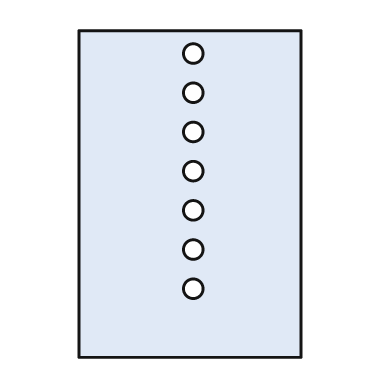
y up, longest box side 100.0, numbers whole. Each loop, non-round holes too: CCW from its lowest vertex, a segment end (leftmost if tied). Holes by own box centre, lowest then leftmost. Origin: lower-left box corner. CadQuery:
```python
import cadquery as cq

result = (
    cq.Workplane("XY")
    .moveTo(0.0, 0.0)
    .lineTo(68.0, 0.0)
    .lineTo(68.0, 100.0)
    .lineTo(0.0, 100.0)
    .close()
    .moveTo(35.0, 21.0)
    .circle(3.0)
    .moveTo(35.0, 33.0)
    .circle(3.0)
    .moveTo(35.0, 45.0)
    .circle(3.0)
    .moveTo(35.0, 57.0)
    .circle(3.0)
    .moveTo(35.0, 69.0)
    .circle(3.0)
    .moveTo(35.0, 81.0)
    .circle(3.0)
    .moveTo(35.0, 93.0)
    .circle(3.0)
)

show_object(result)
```